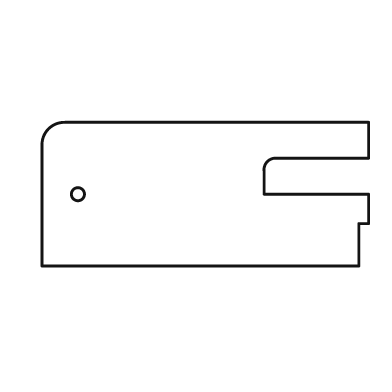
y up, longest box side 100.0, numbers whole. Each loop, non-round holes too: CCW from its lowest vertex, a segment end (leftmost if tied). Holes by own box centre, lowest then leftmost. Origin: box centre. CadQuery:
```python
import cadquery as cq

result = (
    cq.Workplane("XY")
    .moveTo(-50.0, -22.0)
    .lineTo(47.0, -22.0)
    .lineTo(47.0, -9.0)
    .lineTo(50.0, -9.0)
    .lineTo(50.0, 0.0)
    .lineTo(18.0, 0.0)
    .lineTo(18.0, 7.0)
    .threePointArc((19.0, 10.0), (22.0, 11.0))
    .lineTo(50.0, 11.0)
    .lineTo(50.0, 22.0)
    .lineTo(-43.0, 22.0)
    .threePointArc((-48.0, 20.0), (-50.0, 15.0))
    .close()
    .moveTo(-39.0, 0.0)
    .circle(2.0)
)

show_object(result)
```